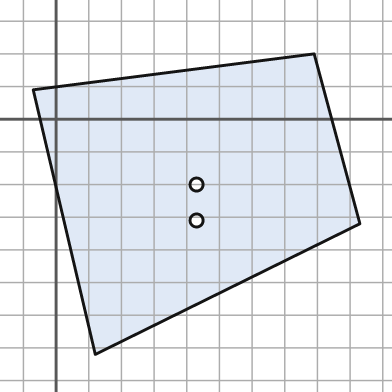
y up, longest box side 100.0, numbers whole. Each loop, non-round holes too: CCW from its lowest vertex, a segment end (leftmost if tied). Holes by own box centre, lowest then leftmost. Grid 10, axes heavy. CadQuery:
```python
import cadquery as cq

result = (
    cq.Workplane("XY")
    .moveTo(12.0, -72.0)
    .lineTo(93.0, -32.0)
    .lineTo(79.0, 20.0)
    .lineTo(-7.0, 9.0)
    .close()
    .moveTo(43.0, -31.0)
    .circle(2.0)
    .moveTo(43.0, -20.0)
    .circle(2.0)
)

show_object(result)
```